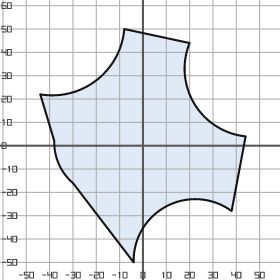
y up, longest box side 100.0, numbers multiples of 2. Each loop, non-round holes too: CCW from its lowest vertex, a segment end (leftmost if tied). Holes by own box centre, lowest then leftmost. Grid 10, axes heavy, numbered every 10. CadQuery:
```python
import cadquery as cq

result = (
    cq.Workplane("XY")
    .moveTo(-4.0, -50.0)
    .threePointArc((10.0, -26.0), (38.0, -28.0))
    .lineTo(44.0, 4.0)
    .threePointArc((22.0, 18.0), (20.0, 44.0))
    .lineTo(-8.0, 50.0)
    .threePointArc((-20.0, 28.0), (-44.0, 22.0))
    .lineTo(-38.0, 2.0)
    .threePointArc((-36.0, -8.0), (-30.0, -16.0))
    .close()
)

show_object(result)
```